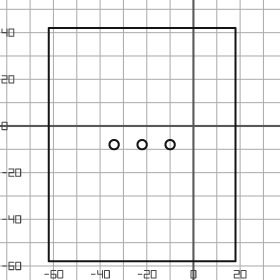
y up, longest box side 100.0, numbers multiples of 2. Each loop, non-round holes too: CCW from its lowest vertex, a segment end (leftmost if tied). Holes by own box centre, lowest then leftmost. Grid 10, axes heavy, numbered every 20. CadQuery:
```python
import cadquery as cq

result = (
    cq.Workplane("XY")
    .moveTo(-62.0, -58.0)
    .lineTo(18.0, -58.0)
    .lineTo(18.0, 42.0)
    .lineTo(-62.0, 42.0)
    .close()
    .moveTo(-34.0, -8.0)
    .circle(2.0)
    .moveTo(-22.0, -8.0)
    .circle(2.0)
    .moveTo(-10.0, -8.0)
    .circle(2.0)
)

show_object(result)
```